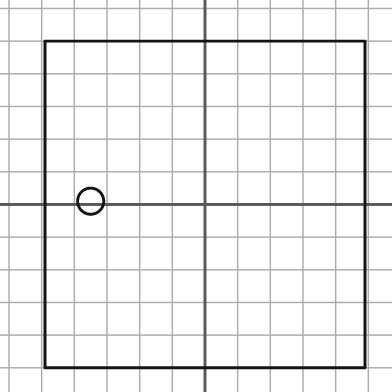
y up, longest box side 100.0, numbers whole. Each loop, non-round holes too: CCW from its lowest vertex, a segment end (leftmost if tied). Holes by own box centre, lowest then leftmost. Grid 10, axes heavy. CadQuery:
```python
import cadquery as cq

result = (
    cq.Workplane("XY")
    .moveTo(-49.0, -50.0)
    .lineTo(49.0, -50.0)
    .lineTo(49.0, 50.0)
    .lineTo(-49.0, 50.0)
    .close()
    .moveTo(-35.0, 1.0)
    .circle(4.0)
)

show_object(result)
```